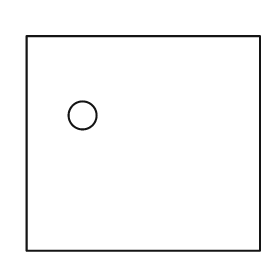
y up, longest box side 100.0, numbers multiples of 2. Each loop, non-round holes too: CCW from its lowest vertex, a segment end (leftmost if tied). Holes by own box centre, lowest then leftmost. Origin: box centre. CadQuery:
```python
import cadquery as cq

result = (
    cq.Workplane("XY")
    .moveTo(-50.0, -46.0)
    .lineTo(50.0, -46.0)
    .lineTo(50.0, 46.0)
    .lineTo(-50.0, 46.0)
    .close()
    .moveTo(-26.0, 12.0)
    .circle(6.0)
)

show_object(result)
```